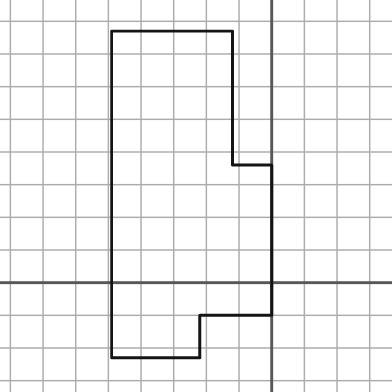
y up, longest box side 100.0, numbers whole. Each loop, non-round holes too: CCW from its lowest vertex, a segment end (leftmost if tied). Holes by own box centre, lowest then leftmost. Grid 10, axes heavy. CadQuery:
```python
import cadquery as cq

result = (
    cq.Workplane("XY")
    .moveTo(-49.0, -23.0)
    .lineTo(-22.0, -23.0)
    .lineTo(-22.0, -10.0)
    .lineTo(0.0, -10.0)
    .lineTo(0.0, 36.0)
    .lineTo(-12.0, 36.0)
    .lineTo(-12.0, 77.0)
    .lineTo(-49.0, 77.0)
    .close()
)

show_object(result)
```